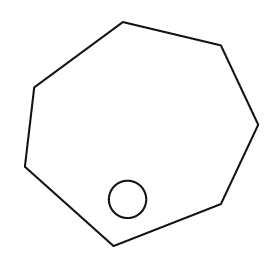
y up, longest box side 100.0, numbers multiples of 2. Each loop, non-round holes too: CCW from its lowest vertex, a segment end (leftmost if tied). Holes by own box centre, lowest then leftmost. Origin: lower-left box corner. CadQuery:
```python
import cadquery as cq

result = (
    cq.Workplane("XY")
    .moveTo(38.0, 0.0)
    .lineTo(84.0, 18.0)
    .lineTo(100.0, 52.0)
    .lineTo(84.0, 86.0)
    .lineTo(42.0, 96.0)
    .lineTo(4.0, 68.0)
    .lineTo(0.0, 34.0)
    .close()
    .moveTo(44.0, 20.0)
    .circle(8.0)
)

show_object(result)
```